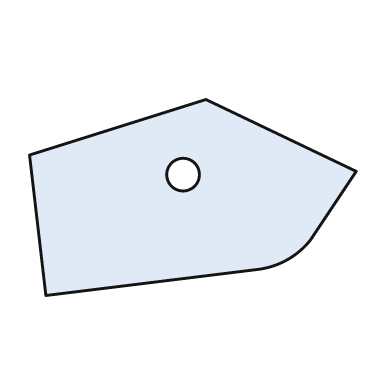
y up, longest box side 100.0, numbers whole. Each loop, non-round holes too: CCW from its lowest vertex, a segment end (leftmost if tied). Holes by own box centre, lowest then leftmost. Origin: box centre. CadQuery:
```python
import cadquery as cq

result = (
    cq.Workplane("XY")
    .moveTo(-45.0, -30.0)
    .lineTo(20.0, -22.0)
    .threePointArc((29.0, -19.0), (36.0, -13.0))
    .lineTo(50.0, 8.0)
    .lineTo(4.0, 30.0)
    .lineTo(-50.0, 13.0)
    .close()
    .moveTo(-3.0, 7.0)
    .circle(5.0)
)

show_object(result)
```